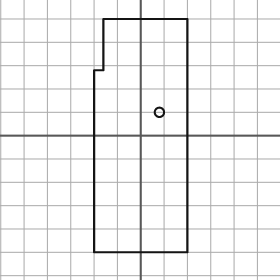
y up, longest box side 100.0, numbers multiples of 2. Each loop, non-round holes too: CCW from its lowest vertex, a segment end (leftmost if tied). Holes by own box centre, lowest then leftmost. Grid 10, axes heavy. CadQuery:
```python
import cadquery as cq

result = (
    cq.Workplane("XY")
    .moveTo(-20.0, -50.0)
    .lineTo(20.0, -50.0)
    .lineTo(20.0, 50.0)
    .lineTo(-16.0, 50.0)
    .lineTo(-16.0, 28.0)
    .lineTo(-20.0, 28.0)
    .close()
    .moveTo(8.0, 10.0)
    .circle(2.0)
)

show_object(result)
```